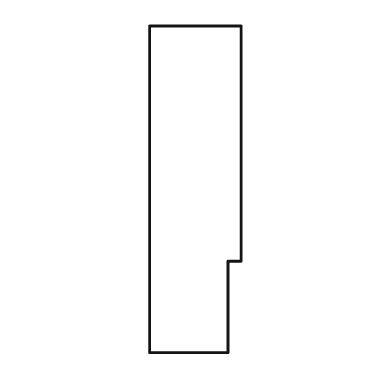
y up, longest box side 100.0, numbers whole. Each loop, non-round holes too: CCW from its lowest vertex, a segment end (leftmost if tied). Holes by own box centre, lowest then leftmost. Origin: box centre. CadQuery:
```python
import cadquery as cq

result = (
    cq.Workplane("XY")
    .moveTo(-14.0, -50.0)
    .lineTo(10.0, -50.0)
    .lineTo(10.0, -22.0)
    .lineTo(14.0, -22.0)
    .lineTo(14.0, 50.0)
    .lineTo(-14.0, 50.0)
    .close()
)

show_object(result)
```